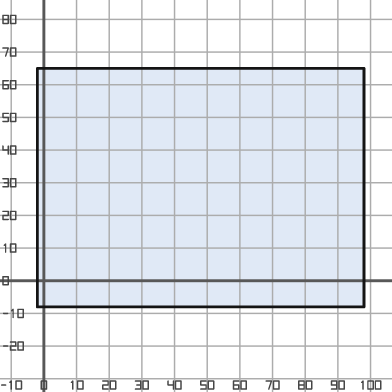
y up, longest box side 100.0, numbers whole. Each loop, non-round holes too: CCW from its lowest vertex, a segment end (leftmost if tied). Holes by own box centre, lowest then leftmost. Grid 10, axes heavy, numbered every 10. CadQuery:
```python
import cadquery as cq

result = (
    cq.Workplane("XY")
    .moveTo(-2.0, -8.0)
    .lineTo(98.0, -8.0)
    .lineTo(98.0, 65.0)
    .lineTo(-2.0, 65.0)
    .close()
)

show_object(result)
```